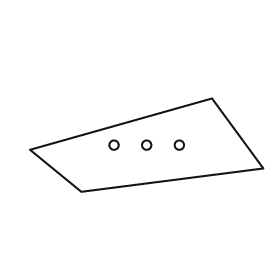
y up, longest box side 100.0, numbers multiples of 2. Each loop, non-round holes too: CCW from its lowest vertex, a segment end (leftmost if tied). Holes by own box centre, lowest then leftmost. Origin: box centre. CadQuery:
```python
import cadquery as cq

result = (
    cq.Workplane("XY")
    .moveTo(-28.0, -20.0)
    .lineTo(50.0, -10.0)
    .lineTo(28.0, 20.0)
    .lineTo(-50.0, -2.0)
    .close()
    .moveTo(-14.0, 0.0)
    .circle(2.0)
    .moveTo(0.0, 0.0)
    .circle(2.0)
    .moveTo(14.0, 0.0)
    .circle(2.0)
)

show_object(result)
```